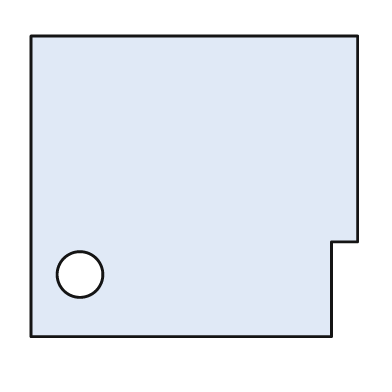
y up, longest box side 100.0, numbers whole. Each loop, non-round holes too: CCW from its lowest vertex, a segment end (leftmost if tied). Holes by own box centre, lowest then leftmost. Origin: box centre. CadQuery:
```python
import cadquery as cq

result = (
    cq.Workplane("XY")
    .moveTo(-50.0, -46.0)
    .lineTo(42.0, -46.0)
    .lineTo(42.0, -17.0)
    .lineTo(50.0, -17.0)
    .lineTo(50.0, 46.0)
    .lineTo(-50.0, 46.0)
    .close()
    .moveTo(-35.0, -27.0)
    .circle(7.0)
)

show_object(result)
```